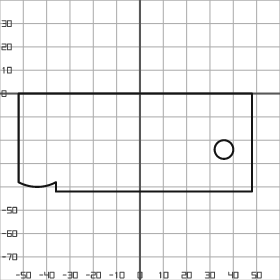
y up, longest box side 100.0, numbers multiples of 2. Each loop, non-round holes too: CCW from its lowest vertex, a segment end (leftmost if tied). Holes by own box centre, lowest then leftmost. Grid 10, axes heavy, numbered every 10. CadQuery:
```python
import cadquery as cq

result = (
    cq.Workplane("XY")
    .moveTo(-36.0, -42.0)
    .lineTo(48.0, -42.0)
    .lineTo(48.0, 0.0)
    .lineTo(-52.0, 0.0)
    .lineTo(-52.0, -38.0)
    .threePointArc((-44.0, -40.0), (-36.0, -38.0))
    .close()
    .moveTo(36.0, -24.0)
    .circle(4.0)
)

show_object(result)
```